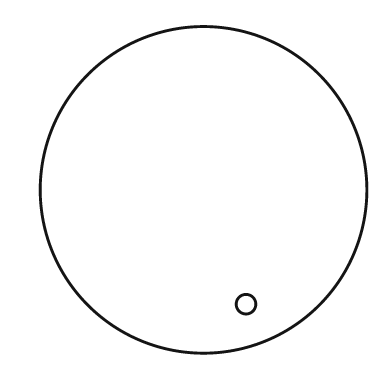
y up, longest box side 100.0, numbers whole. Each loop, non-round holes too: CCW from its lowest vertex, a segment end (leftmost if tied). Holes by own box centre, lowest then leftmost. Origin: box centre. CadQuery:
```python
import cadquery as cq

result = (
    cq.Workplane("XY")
    .moveTo(0.0, 0.0)
    .circle(50.0)
    .moveTo(13.0, -35.0)
    .circle(3.0)
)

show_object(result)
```